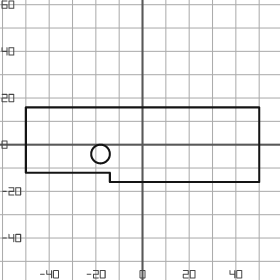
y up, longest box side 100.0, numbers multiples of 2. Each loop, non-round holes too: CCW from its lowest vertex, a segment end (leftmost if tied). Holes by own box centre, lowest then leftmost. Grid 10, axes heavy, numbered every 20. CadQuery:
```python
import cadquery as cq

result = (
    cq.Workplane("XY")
    .moveTo(-14.0, -16.0)
    .lineTo(50.0, -16.0)
    .lineTo(50.0, 16.0)
    .lineTo(-50.0, 16.0)
    .lineTo(-50.0, -12.0)
    .lineTo(-14.0, -12.0)
    .close()
    .moveTo(-18.0, -4.0)
    .circle(4.0)
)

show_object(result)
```